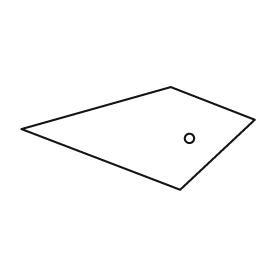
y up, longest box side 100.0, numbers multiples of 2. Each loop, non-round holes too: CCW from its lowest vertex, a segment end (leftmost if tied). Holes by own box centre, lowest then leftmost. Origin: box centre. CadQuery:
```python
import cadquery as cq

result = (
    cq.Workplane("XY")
    .moveTo(18.0, -22.0)
    .lineTo(50.0, 8.0)
    .lineTo(14.0, 22.0)
    .lineTo(-50.0, 4.0)
    .close()
    .moveTo(22.0, 0.0)
    .circle(2.0)
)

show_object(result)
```